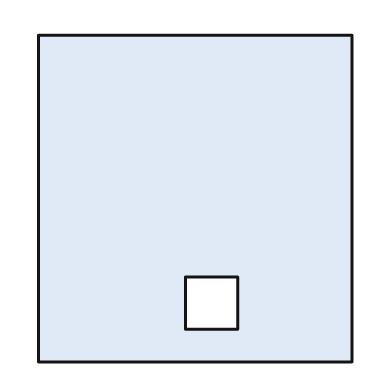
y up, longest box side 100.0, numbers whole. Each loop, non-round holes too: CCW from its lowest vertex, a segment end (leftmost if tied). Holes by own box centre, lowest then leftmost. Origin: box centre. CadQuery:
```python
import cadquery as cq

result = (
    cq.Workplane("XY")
    .moveTo(-48.0, -50.0)
    .lineTo(48.0, -50.0)
    .lineTo(48.0, 50.0)
    .lineTo(-48.0, 50.0)
    .close()
    .moveTo(-3.0, -40.0)
    .lineTo(13.0, -40.0)
    .lineTo(13.0, -24.0)
    .lineTo(-3.0, -24.0)
    .close()
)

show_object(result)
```